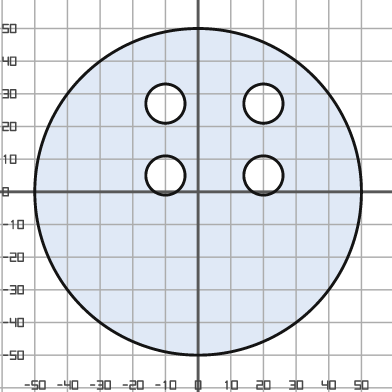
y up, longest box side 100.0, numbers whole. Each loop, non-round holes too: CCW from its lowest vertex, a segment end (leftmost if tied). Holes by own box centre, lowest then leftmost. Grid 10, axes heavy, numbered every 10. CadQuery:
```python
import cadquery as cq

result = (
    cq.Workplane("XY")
    .moveTo(0.0, 0.0)
    .circle(50.0)
    .moveTo(-10.0, 5.0)
    .circle(6.0)
    .moveTo(20.0, 5.0)
    .circle(6.0)
    .moveTo(-10.0, 27.0)
    .circle(6.0)
    .moveTo(20.0, 27.0)
    .circle(6.0)
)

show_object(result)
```